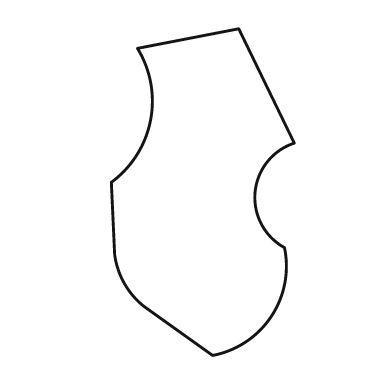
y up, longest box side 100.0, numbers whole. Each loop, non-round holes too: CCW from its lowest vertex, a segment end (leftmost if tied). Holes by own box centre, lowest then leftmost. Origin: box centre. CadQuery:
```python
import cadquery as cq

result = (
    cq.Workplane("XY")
    .moveTo(3.0, -50.0)
    .threePointArc((21.0, -38.0), (25.0, -17.0))
    .threePointArc((16.0, 0.0), (28.0, 15.0))
    .lineTo(11.0, 50.0)
    .lineTo(-20.0, 44.0)
    .threePointArc((-16.0, 22.0), (-28.0, 3.0))
    .lineTo(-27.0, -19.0)
    .threePointArc((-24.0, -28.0), (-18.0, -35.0))
    .close()
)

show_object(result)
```